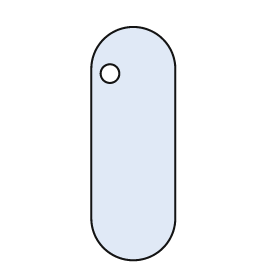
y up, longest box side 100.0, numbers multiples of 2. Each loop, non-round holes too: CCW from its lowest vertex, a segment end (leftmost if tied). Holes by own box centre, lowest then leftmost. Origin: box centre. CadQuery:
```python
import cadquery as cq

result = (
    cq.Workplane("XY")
    .moveTo(-18.0, -32.0)
    .threePointArc((0.0, -50.0), (18.0, -32.0))
    .lineTo(18.0, 32.0)
    .threePointArc((0.0, 50.0), (-18.0, 32.0))
    .close()
    .moveTo(-10.0, 30.0)
    .circle(4.0)
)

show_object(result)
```